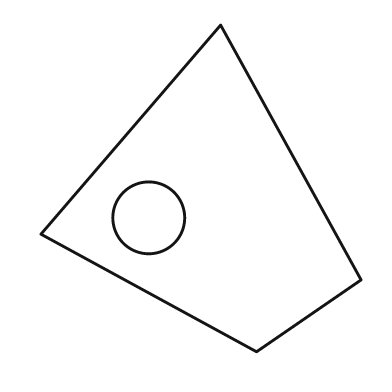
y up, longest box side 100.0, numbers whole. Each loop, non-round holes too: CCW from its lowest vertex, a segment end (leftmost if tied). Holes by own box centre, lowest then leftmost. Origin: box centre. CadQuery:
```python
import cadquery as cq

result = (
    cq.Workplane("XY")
    .moveTo(17.0, -50.0)
    .lineTo(49.0, -28.0)
    .lineTo(6.0, 50.0)
    .lineTo(-49.0, -14.0)
    .close()
    .moveTo(-16.0, -9.0)
    .circle(11.0)
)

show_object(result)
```